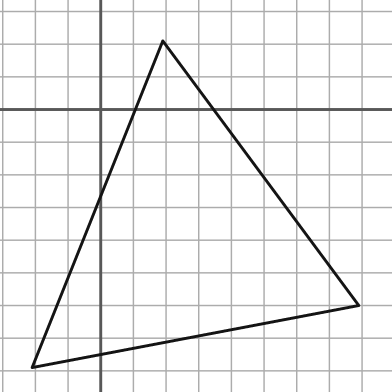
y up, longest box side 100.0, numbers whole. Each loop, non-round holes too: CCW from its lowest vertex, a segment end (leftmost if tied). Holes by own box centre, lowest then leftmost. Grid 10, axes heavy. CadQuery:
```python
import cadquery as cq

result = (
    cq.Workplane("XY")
    .moveTo(-21.0, -79.0)
    .lineTo(79.0, -60.0)
    .lineTo(19.0, 21.0)
    .close()
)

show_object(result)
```